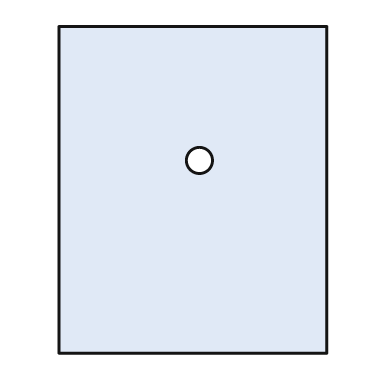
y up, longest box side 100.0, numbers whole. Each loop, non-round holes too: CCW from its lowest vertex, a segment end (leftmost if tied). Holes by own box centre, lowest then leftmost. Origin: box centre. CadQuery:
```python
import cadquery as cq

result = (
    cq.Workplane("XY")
    .moveTo(-41.0, -50.0)
    .lineTo(41.0, -50.0)
    .lineTo(41.0, 50.0)
    .lineTo(-41.0, 50.0)
    .close()
    .moveTo(2.0, 9.0)
    .circle(4.0)
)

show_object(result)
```